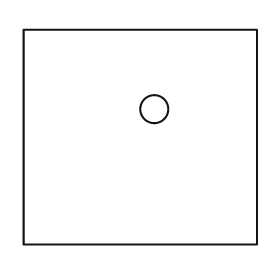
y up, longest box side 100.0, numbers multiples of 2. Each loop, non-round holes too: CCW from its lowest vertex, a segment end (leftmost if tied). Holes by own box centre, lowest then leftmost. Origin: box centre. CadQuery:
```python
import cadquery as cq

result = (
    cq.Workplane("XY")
    .moveTo(-50.0, -46.0)
    .lineTo(50.0, -46.0)
    .lineTo(50.0, 46.0)
    .lineTo(-50.0, 46.0)
    .close()
    .moveTo(6.0, 12.0)
    .circle(6.0)
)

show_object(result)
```